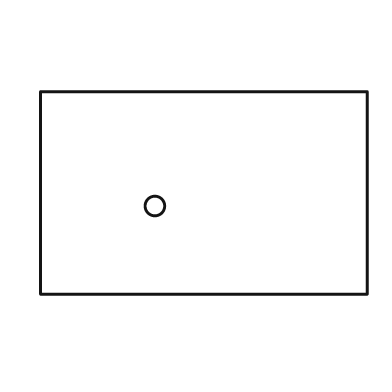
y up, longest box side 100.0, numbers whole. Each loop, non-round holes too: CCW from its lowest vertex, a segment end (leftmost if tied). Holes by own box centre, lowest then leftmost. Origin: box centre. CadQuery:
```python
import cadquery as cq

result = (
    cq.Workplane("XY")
    .moveTo(-50.0, -31.0)
    .lineTo(50.0, -31.0)
    .lineTo(50.0, 31.0)
    .lineTo(-50.0, 31.0)
    .close()
    .moveTo(-15.0, -4.0)
    .circle(3.0)
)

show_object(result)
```